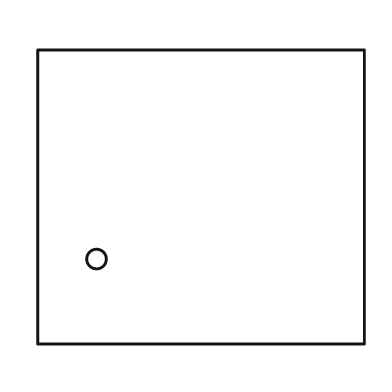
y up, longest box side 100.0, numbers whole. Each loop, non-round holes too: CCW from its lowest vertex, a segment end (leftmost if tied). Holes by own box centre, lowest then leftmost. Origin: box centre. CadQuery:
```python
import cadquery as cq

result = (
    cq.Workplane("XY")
    .moveTo(-50.0, -45.0)
    .lineTo(50.0, -45.0)
    .lineTo(50.0, 45.0)
    .lineTo(-50.0, 45.0)
    .close()
    .moveTo(-32.0, -19.0)
    .circle(3.0)
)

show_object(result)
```